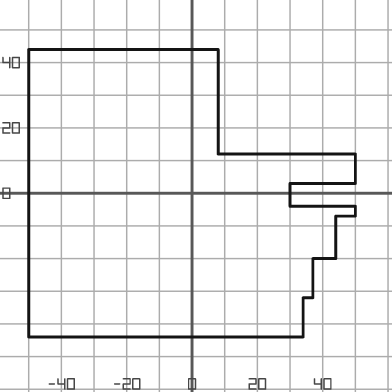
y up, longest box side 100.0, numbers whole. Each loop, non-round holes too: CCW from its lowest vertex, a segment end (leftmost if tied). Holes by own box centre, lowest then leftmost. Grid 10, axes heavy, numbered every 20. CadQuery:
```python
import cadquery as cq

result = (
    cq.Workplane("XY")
    .moveTo(-50.0, -44.0)
    .lineTo(34.0, -44.0)
    .lineTo(34.0, -32.0)
    .lineTo(37.0, -32.0)
    .lineTo(37.0, -20.0)
    .lineTo(44.0, -20.0)
    .lineTo(44.0, -7.0)
    .lineTo(50.0, -7.0)
    .lineTo(50.0, -4.0)
    .lineTo(30.0, -4.0)
    .lineTo(30.0, 3.0)
    .lineTo(50.0, 3.0)
    .lineTo(50.0, 12.0)
    .lineTo(8.0, 12.0)
    .lineTo(8.0, 44.0)
    .lineTo(-50.0, 44.0)
    .close()
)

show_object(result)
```